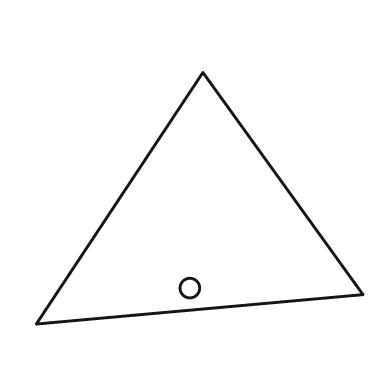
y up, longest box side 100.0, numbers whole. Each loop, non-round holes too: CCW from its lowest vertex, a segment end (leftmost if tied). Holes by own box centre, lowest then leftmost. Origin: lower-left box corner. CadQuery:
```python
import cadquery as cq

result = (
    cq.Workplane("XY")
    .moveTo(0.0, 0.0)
    .lineTo(100.0, 9.0)
    .lineTo(51.0, 77.0)
    .close()
    .moveTo(47.0, 11.0)
    .circle(3.0)
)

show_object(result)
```